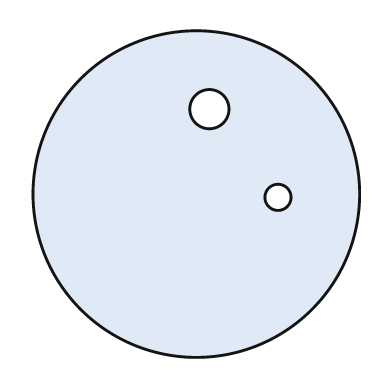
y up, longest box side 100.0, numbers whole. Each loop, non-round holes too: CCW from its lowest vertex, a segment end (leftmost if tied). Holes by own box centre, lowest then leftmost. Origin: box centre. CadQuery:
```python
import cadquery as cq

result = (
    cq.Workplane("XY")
    .moveTo(0.0, 0.0)
    .circle(50.0)
    .moveTo(25.0, -1.0)
    .circle(4.0)
    .moveTo(4.0, 26.0)
    .circle(6.0)
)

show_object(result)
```